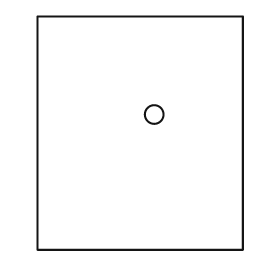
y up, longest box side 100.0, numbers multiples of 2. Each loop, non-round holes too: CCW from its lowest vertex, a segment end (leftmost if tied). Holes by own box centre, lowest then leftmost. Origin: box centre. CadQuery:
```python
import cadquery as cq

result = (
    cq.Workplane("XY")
    .moveTo(-44.0, -50.0)
    .lineTo(44.0, -50.0)
    .lineTo(44.0, 50.0)
    .lineTo(-44.0, 50.0)
    .close()
    .moveTo(6.0, 8.0)
    .circle(4.0)
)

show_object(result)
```